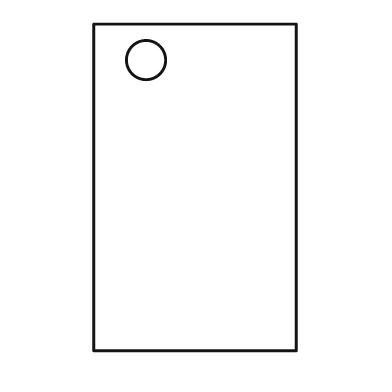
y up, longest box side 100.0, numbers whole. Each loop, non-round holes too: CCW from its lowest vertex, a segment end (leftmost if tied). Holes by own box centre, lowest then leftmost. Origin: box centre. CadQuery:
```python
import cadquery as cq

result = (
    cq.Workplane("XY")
    .moveTo(-31.0, -50.0)
    .lineTo(31.0, -50.0)
    .lineTo(31.0, 50.0)
    .lineTo(-31.0, 50.0)
    .close()
    .moveTo(-15.0, 39.0)
    .circle(6.0)
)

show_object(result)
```